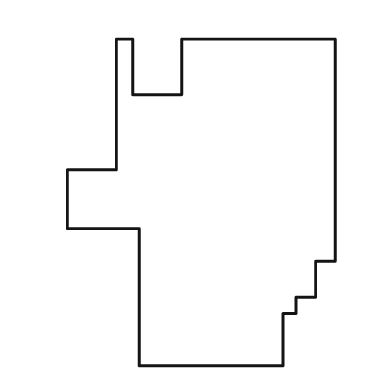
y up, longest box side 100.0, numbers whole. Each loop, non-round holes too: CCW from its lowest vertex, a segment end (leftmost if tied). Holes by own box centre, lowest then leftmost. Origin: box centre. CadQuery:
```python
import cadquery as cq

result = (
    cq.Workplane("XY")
    .moveTo(-19.0, -50.0)
    .lineTo(25.0, -50.0)
    .lineTo(25.0, -34.0)
    .lineTo(29.0, -34.0)
    .lineTo(29.0, -29.0)
    .lineTo(35.0, -29.0)
    .lineTo(35.0, -18.0)
    .lineTo(41.0, -18.0)
    .lineTo(41.0, 50.0)
    .lineTo(-6.0, 50.0)
    .lineTo(-6.0, 33.0)
    .lineTo(-21.0, 33.0)
    .lineTo(-21.0, 50.0)
    .lineTo(-26.0, 50.0)
    .lineTo(-26.0, 10.0)
    .lineTo(-41.0, 10.0)
    .lineTo(-41.0, -8.0)
    .lineTo(-19.0, -8.0)
    .close()
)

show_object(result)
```